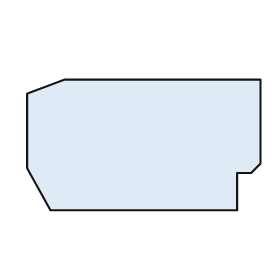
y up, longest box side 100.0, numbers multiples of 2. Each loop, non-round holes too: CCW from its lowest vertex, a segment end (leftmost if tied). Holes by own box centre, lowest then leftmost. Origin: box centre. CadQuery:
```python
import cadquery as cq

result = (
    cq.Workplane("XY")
    .moveTo(-40.0, -28.0)
    .lineTo(40.0, -28.0)
    .lineTo(40.0, -12.0)
    .lineTo(46.0, -12.0)
    .lineTo(50.0, -8.0)
    .lineTo(50.0, 28.0)
    .lineTo(-34.0, 28.0)
    .lineTo(-50.0, 22.0)
    .lineTo(-50.0, -10.0)
    .close()
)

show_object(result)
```